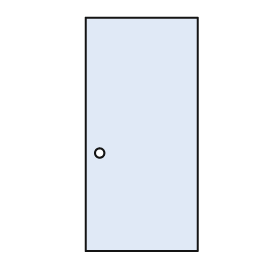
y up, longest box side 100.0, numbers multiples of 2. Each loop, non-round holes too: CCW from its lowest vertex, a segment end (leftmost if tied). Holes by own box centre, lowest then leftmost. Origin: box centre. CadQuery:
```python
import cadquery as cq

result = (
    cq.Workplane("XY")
    .moveTo(-24.0, -50.0)
    .lineTo(24.0, -50.0)
    .lineTo(24.0, 50.0)
    .lineTo(-24.0, 50.0)
    .close()
    .moveTo(-18.0, -8.0)
    .circle(2.0)
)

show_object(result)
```